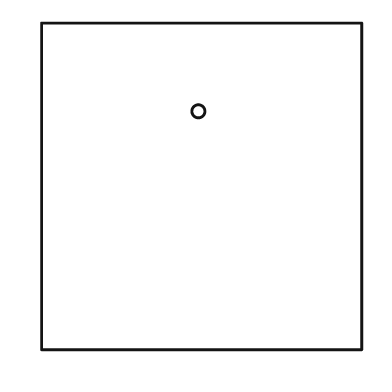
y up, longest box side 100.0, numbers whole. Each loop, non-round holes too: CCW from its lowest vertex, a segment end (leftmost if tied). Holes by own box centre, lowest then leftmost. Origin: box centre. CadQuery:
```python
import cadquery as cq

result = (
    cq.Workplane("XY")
    .moveTo(-49.0, -50.0)
    .lineTo(49.0, -50.0)
    .lineTo(49.0, 50.0)
    .lineTo(-49.0, 50.0)
    .close()
    .moveTo(-1.0, 23.0)
    .circle(2.0)
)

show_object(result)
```